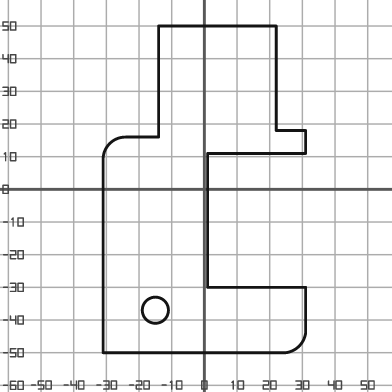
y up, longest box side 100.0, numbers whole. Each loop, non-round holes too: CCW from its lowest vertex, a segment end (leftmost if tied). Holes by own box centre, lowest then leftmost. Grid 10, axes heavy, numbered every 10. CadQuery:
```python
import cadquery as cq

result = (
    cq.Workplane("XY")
    .moveTo(-31.0, -50.0)
    .lineTo(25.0, -50.0)
    .threePointArc((29.0, -48.0), (31.0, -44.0))
    .lineTo(31.0, -30.0)
    .lineTo(1.0, -30.0)
    .lineTo(1.0, 11.0)
    .lineTo(31.0, 11.0)
    .lineTo(31.0, 18.0)
    .lineTo(22.0, 18.0)
    .lineTo(22.0, 50.0)
    .lineTo(-14.0, 50.0)
    .lineTo(-14.0, 16.0)
    .lineTo(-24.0, 16.0)
    .threePointArc((-29.0, 14.0), (-31.0, 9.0))
    .close()
    .moveTo(-15.0, -37.0)
    .circle(4.0)
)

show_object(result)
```